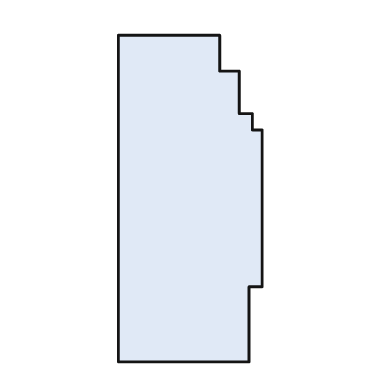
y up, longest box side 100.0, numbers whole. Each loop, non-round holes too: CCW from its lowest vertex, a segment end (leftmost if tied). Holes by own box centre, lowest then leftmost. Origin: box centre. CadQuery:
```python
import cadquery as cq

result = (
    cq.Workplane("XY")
    .moveTo(-22.0, -50.0)
    .lineTo(18.0, -50.0)
    .lineTo(18.0, -27.0)
    .lineTo(22.0, -27.0)
    .lineTo(22.0, 21.0)
    .lineTo(19.0, 21.0)
    .lineTo(19.0, 26.0)
    .lineTo(15.0, 26.0)
    .lineTo(15.0, 39.0)
    .lineTo(9.0, 39.0)
    .lineTo(9.0, 50.0)
    .lineTo(-22.0, 50.0)
    .close()
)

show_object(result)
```